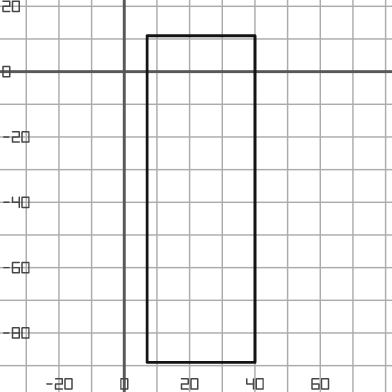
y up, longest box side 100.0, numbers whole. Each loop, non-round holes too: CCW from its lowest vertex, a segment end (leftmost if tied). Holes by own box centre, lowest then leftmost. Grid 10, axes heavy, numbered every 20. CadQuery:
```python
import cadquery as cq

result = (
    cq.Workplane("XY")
    .moveTo(7.0, -89.0)
    .lineTo(40.0, -89.0)
    .lineTo(40.0, 11.0)
    .lineTo(7.0, 11.0)
    .close()
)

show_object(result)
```